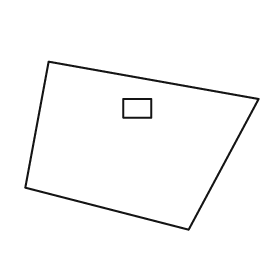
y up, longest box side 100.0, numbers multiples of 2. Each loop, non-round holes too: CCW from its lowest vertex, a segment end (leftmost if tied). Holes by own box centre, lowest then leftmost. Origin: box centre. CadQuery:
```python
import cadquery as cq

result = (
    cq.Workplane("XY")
    .moveTo(20.0, -36.0)
    .lineTo(50.0, 20.0)
    .lineTo(-40.0, 36.0)
    .lineTo(-50.0, -18.0)
    .close()
    .moveTo(-8.0, 12.0)
    .lineTo(4.0, 12.0)
    .lineTo(4.0, 20.0)
    .lineTo(-8.0, 20.0)
    .close()
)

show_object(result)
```